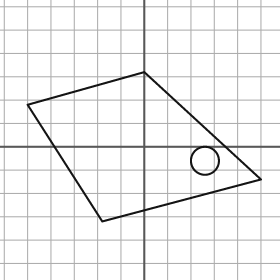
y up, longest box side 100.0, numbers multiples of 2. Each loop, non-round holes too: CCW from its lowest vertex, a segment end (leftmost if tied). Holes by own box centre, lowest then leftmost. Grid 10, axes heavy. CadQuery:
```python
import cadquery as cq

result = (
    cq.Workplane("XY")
    .moveTo(-18.0, -32.0)
    .lineTo(50.0, -14.0)
    .lineTo(0.0, 32.0)
    .lineTo(-50.0, 18.0)
    .close()
    .moveTo(26.0, -6.0)
    .circle(6.0)
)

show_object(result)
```